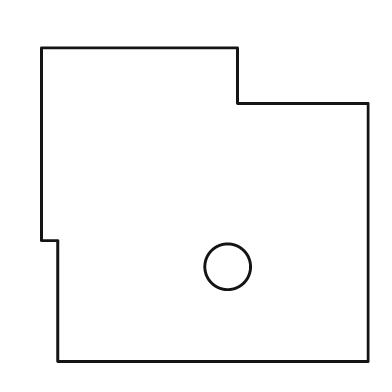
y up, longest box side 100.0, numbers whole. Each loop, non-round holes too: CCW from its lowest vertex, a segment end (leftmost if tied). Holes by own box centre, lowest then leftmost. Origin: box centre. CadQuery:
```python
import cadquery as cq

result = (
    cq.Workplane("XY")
    .moveTo(-45.0, -48.0)
    .lineTo(50.0, -48.0)
    .lineTo(50.0, 31.0)
    .lineTo(10.0, 31.0)
    .lineTo(10.0, 48.0)
    .lineTo(-50.0, 48.0)
    .lineTo(-50.0, -11.0)
    .lineTo(-45.0, -11.0)
    .close()
    .moveTo(7.0, -19.0)
    .circle(7.0)
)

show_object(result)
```